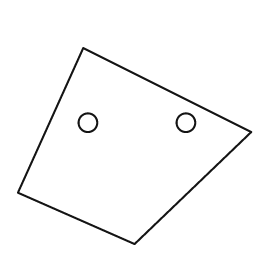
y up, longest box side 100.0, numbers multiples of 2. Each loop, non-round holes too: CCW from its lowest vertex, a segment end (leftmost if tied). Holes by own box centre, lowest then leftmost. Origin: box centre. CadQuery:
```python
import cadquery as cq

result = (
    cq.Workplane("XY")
    .moveTo(0.0, -42.0)
    .lineTo(50.0, 6.0)
    .lineTo(-22.0, 42.0)
    .lineTo(-50.0, -20.0)
    .close()
    .moveTo(-20.0, 10.0)
    .circle(4.0)
    .moveTo(22.0, 10.0)
    .circle(4.0)
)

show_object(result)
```